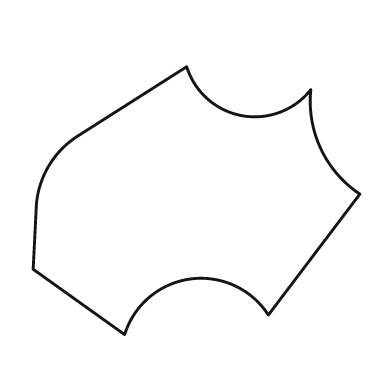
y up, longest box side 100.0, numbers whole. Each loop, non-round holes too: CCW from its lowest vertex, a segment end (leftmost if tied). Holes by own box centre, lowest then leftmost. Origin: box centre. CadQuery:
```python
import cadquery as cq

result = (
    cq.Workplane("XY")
    .moveTo(-22.0, -41.0)
    .threePointArc((-2.0, -24.0), (22.0, -35.0))
    .lineTo(50.0, 2.0)
    .threePointArc((38.0, 16.0), (35.0, 34.0))
    .threePointArc((14.0, 26.0), (-3.0, 41.0))
    .lineTo(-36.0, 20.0)
    .threePointArc((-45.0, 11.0), (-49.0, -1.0))
    .lineTo(-50.0, -21.0)
    .close()
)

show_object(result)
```